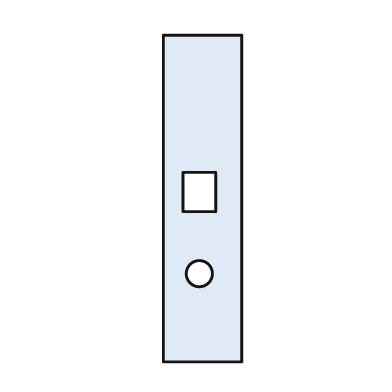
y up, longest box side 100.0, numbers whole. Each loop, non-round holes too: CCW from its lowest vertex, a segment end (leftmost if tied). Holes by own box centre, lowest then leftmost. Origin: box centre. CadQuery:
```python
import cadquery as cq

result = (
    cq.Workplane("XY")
    .moveTo(-12.0, -50.0)
    .lineTo(12.0, -50.0)
    .lineTo(12.0, 50.0)
    .lineTo(-12.0, 50.0)
    .close()
    .moveTo(-1.0, -23.0)
    .circle(4.0)
    .moveTo(-6.0, -4.0)
    .lineTo(4.0, -4.0)
    .lineTo(4.0, 8.0)
    .lineTo(-6.0, 8.0)
    .close()
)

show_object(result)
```